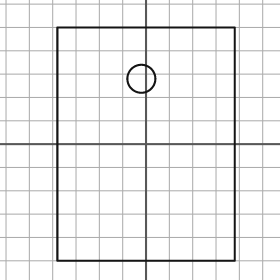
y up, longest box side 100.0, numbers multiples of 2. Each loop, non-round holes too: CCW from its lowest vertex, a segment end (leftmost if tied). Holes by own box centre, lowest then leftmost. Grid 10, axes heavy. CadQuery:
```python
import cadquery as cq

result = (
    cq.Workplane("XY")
    .moveTo(-38.0, -50.0)
    .lineTo(38.0, -50.0)
    .lineTo(38.0, 50.0)
    .lineTo(-38.0, 50.0)
    .close()
    .moveTo(-2.0, 28.0)
    .circle(6.0)
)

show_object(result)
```